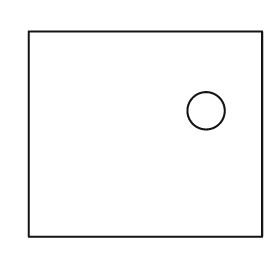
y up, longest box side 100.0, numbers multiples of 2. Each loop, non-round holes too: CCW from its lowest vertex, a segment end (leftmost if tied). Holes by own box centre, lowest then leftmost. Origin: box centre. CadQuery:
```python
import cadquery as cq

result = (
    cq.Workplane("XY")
    .moveTo(-50.0, -44.0)
    .lineTo(50.0, -44.0)
    .lineTo(50.0, 44.0)
    .lineTo(-50.0, 44.0)
    .close()
    .moveTo(26.0, 10.0)
    .circle(8.0)
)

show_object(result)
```